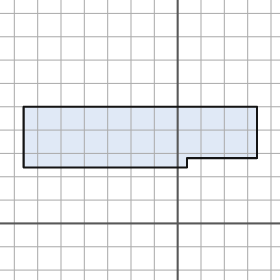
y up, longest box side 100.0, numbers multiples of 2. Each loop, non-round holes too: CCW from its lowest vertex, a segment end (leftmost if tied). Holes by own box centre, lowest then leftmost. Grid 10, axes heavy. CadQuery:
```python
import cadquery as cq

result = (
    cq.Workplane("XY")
    .moveTo(-66.0, 24.0)
    .lineTo(4.0, 24.0)
    .lineTo(4.0, 28.0)
    .lineTo(34.0, 28.0)
    .lineTo(34.0, 50.0)
    .lineTo(-66.0, 50.0)
    .close()
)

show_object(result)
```